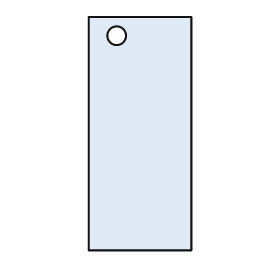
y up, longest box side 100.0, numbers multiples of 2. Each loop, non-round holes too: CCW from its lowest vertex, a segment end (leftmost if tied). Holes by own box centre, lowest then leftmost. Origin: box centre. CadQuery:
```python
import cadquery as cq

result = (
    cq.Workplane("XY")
    .moveTo(-22.0, -50.0)
    .lineTo(22.0, -50.0)
    .lineTo(22.0, 50.0)
    .lineTo(-22.0, 50.0)
    .close()
    .moveTo(-10.0, 42.0)
    .circle(4.0)
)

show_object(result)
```